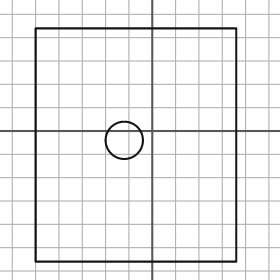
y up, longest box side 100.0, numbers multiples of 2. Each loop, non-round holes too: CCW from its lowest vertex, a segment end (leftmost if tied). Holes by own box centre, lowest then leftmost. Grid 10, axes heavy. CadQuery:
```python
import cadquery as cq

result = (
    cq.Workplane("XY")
    .moveTo(-50.0, -56.0)
    .lineTo(36.0, -56.0)
    .lineTo(36.0, 44.0)
    .lineTo(-50.0, 44.0)
    .close()
    .moveTo(-12.0, -4.0)
    .circle(8.0)
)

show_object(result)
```